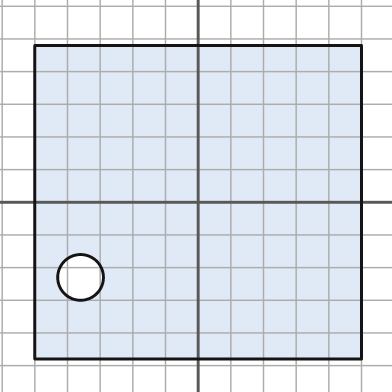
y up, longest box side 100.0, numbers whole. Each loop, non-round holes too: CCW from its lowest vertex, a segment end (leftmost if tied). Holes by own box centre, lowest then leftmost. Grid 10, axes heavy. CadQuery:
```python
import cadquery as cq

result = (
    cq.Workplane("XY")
    .moveTo(-50.0, -48.0)
    .lineTo(50.0, -48.0)
    .lineTo(50.0, 48.0)
    .lineTo(-50.0, 48.0)
    .close()
    .moveTo(-36.0, -23.0)
    .circle(7.0)
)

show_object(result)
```